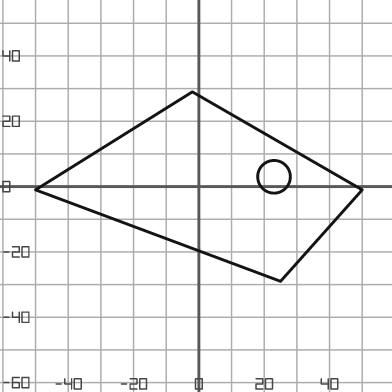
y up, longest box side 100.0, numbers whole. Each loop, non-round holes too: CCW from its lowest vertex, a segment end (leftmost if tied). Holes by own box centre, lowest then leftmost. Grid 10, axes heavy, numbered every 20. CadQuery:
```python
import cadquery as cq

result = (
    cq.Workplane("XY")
    .moveTo(25.0, -29.0)
    .lineTo(50.0, -1.0)
    .lineTo(-2.0, 29.0)
    .lineTo(-50.0, -1.0)
    .close()
    .moveTo(23.0, 3.0)
    .circle(5.0)
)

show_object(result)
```